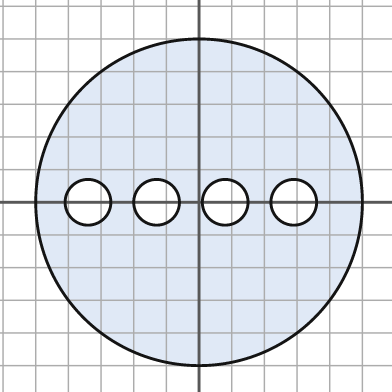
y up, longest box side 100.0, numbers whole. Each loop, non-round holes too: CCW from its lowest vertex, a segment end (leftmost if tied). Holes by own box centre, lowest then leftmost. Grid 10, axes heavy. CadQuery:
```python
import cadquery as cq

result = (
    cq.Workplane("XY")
    .moveTo(0.0, 0.0)
    .circle(50.0)
    .moveTo(-34.0, 0.0)
    .circle(7.0)
    .moveTo(-13.0, 0.0)
    .circle(7.0)
    .moveTo(8.0, 0.0)
    .circle(7.0)
    .moveTo(29.0, 0.0)
    .circle(7.0)
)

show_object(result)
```